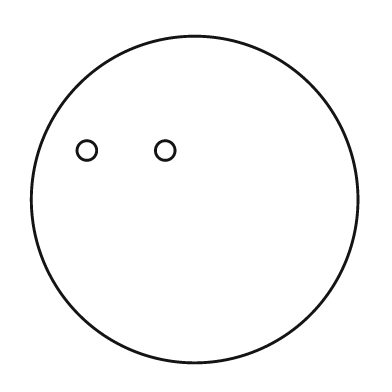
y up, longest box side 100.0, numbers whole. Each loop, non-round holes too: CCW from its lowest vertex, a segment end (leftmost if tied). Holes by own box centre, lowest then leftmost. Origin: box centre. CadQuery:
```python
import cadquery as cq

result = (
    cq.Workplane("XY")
    .moveTo(0.0, 0.0)
    .circle(50.0)
    .moveTo(-33.0, 15.0)
    .circle(3.0)
    .moveTo(-9.0, 15.0)
    .circle(3.0)
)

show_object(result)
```